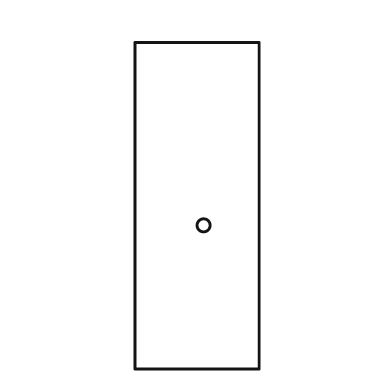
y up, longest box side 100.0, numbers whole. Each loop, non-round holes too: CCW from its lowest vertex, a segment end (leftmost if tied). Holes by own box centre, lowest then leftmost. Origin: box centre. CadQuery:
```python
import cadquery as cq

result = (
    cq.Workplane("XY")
    .moveTo(-19.0, -50.0)
    .lineTo(19.0, -50.0)
    .lineTo(19.0, 50.0)
    .lineTo(-19.0, 50.0)
    .close()
    .moveTo(2.0, -6.0)
    .circle(2.0)
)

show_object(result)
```